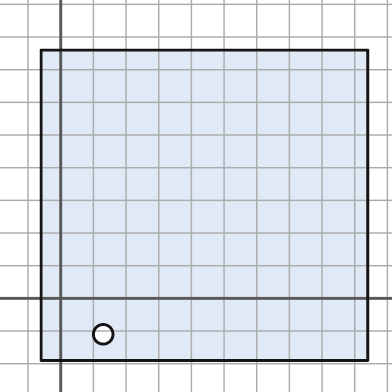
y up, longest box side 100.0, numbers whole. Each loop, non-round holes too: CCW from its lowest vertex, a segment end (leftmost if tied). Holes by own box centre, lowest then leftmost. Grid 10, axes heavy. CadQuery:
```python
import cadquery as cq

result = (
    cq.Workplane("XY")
    .moveTo(-6.0, -19.0)
    .lineTo(94.0, -19.0)
    .lineTo(94.0, 76.0)
    .lineTo(-6.0, 76.0)
    .close()
    .moveTo(13.0, -11.0)
    .circle(3.0)
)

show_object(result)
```